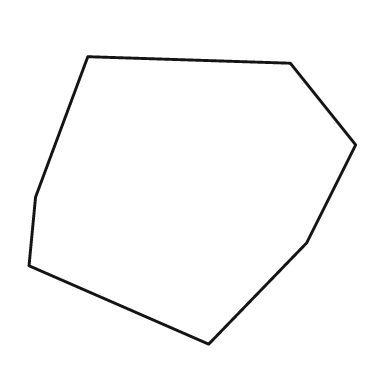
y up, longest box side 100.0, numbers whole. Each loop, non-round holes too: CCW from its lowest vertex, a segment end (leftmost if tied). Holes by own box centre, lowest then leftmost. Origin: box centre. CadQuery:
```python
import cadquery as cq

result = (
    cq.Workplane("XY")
    .moveTo(5.0, -44.0)
    .lineTo(35.0, -13.0)
    .lineTo(50.0, 17.0)
    .lineTo(30.0, 42.0)
    .lineTo(-32.0, 44.0)
    .lineTo(-48.0, 1.0)
    .lineTo(-50.0, -20.0)
    .close()
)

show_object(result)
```